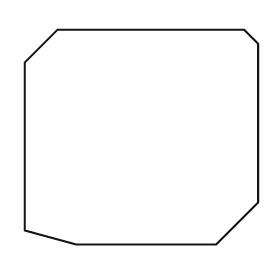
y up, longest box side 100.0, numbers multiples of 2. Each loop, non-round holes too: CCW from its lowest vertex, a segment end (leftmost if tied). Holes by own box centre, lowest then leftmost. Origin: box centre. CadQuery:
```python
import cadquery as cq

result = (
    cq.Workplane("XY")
    .moveTo(-28.0, -46.0)
    .lineTo(32.0, -46.0)
    .lineTo(50.0, -28.0)
    .lineTo(50.0, 40.0)
    .lineTo(44.0, 46.0)
    .lineTo(-36.0, 46.0)
    .lineTo(-50.0, 32.0)
    .lineTo(-50.0, -40.0)
    .close()
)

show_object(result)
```